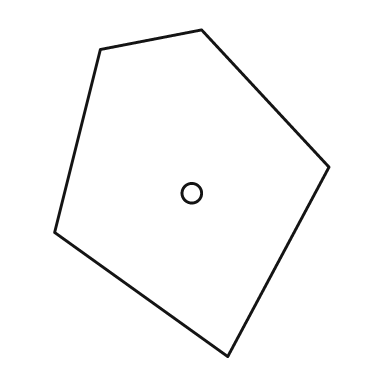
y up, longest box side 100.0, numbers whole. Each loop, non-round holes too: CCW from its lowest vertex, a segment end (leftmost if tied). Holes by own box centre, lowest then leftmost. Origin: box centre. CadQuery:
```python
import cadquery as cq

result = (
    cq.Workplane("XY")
    .moveTo(11.0, -50.0)
    .lineTo(42.0, 8.0)
    .lineTo(3.0, 50.0)
    .lineTo(-28.0, 44.0)
    .lineTo(-42.0, -12.0)
    .close()
    .moveTo(0.0, 0.0)
    .circle(3.0)
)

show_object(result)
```